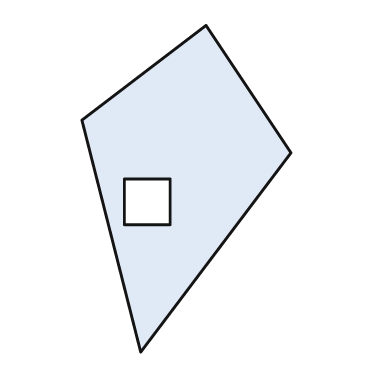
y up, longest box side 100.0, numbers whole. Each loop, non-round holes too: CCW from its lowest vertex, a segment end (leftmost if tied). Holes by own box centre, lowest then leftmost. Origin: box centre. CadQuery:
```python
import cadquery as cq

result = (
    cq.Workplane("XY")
    .moveTo(-14.0, -50.0)
    .lineTo(32.0, 11.0)
    .lineTo(6.0, 50.0)
    .lineTo(-32.0, 21.0)
    .close()
    .moveTo(-19.0, -11.0)
    .lineTo(-5.0, -11.0)
    .lineTo(-5.0, 3.0)
    .lineTo(-19.0, 3.0)
    .close()
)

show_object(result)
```